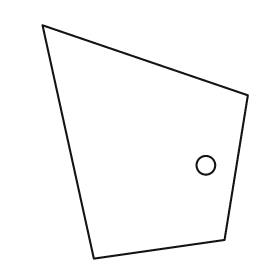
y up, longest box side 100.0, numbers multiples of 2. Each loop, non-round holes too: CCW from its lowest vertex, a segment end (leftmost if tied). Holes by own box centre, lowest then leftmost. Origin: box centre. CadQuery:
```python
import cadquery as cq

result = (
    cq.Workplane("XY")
    .moveTo(-22.0, -50.0)
    .lineTo(34.0, -42.0)
    .lineTo(44.0, 20.0)
    .lineTo(-44.0, 50.0)
    .close()
    .moveTo(26.0, -10.0)
    .circle(4.0)
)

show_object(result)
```